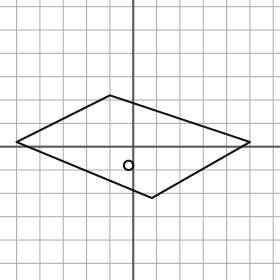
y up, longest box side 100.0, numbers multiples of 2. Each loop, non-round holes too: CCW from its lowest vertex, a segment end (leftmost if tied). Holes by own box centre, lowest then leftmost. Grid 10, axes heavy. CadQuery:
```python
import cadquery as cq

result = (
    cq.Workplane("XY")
    .moveTo(8.0, -22.0)
    .lineTo(50.0, 2.0)
    .lineTo(-10.0, 22.0)
    .lineTo(-50.0, 2.0)
    .close()
    .moveTo(-2.0, -8.0)
    .circle(2.0)
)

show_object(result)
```